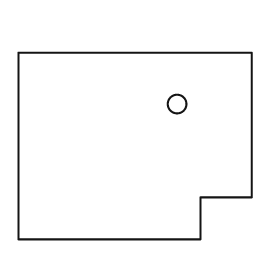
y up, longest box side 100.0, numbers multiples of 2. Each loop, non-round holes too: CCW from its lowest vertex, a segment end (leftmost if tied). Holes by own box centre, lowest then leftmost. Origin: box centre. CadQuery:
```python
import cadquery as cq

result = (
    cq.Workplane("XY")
    .moveTo(-50.0, -40.0)
    .lineTo(28.0, -40.0)
    .lineTo(28.0, -22.0)
    .lineTo(50.0, -22.0)
    .lineTo(50.0, 40.0)
    .lineTo(-50.0, 40.0)
    .close()
    .moveTo(18.0, 18.0)
    .circle(4.0)
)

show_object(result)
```